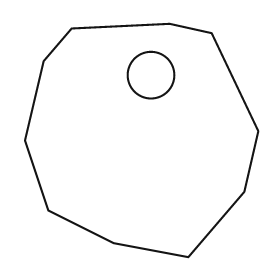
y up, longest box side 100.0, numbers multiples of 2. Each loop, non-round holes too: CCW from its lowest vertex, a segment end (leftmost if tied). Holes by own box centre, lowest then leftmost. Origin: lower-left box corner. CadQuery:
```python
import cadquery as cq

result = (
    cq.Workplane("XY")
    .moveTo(70.0, 0.0)
    .lineTo(94.0, 28.0)
    .lineTo(100.0, 54.0)
    .lineTo(80.0, 96.0)
    .lineTo(62.0, 100.0)
    .lineTo(20.0, 98.0)
    .lineTo(8.0, 84.0)
    .lineTo(0.0, 50.0)
    .lineTo(10.0, 20.0)
    .lineTo(38.0, 6.0)
    .close()
    .moveTo(54.0, 78.0)
    .circle(10.0)
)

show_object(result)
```